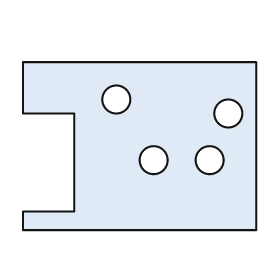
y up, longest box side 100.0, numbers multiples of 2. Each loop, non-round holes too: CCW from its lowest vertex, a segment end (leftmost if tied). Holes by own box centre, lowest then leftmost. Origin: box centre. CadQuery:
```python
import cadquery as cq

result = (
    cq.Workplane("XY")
    .moveTo(-50.0, -36.0)
    .lineTo(50.0, -36.0)
    .lineTo(50.0, 36.0)
    .lineTo(-50.0, 36.0)
    .lineTo(-50.0, 14.0)
    .lineTo(-28.0, 14.0)
    .lineTo(-28.0, -28.0)
    .lineTo(-50.0, -28.0)
    .close()
    .moveTo(6.0, -6.0)
    .circle(6.0)
    .moveTo(30.0, -6.0)
    .circle(6.0)
    .moveTo(38.0, 14.0)
    .circle(6.0)
    .moveTo(-10.0, 20.0)
    .circle(6.0)
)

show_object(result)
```